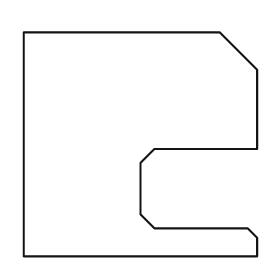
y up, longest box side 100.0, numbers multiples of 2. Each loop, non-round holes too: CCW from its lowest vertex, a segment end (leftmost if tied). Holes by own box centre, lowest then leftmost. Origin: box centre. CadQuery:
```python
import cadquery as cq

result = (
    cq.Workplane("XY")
    .moveTo(-50.0, -48.0)
    .lineTo(50.0, -48.0)
    .lineTo(50.0, -40.0)
    .lineTo(46.0, -36.0)
    .lineTo(6.0, -36.0)
    .lineTo(0.0, -30.0)
    .lineTo(0.0, -8.0)
    .lineTo(6.0, -2.0)
    .lineTo(50.0, -2.0)
    .lineTo(50.0, 32.0)
    .lineTo(34.0, 48.0)
    .lineTo(-50.0, 48.0)
    .close()
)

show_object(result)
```